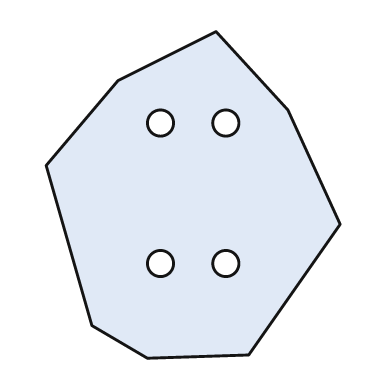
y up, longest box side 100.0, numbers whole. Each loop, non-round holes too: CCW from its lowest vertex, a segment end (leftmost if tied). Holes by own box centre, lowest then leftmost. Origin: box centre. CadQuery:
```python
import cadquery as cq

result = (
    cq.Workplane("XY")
    .moveTo(-14.0, -50.0)
    .lineTo(17.0, -49.0)
    .lineTo(45.0, -9.0)
    .lineTo(29.0, 26.0)
    .lineTo(7.0, 50.0)
    .lineTo(-23.0, 35.0)
    .lineTo(-45.0, 9.0)
    .lineTo(-31.0, -40.0)
    .close()
    .moveTo(-10.0, -21.0)
    .circle(4.0)
    .moveTo(10.0, -21.0)
    .circle(4.0)
    .moveTo(-10.0, 22.0)
    .circle(4.0)
    .moveTo(10.0, 22.0)
    .circle(4.0)
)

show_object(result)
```